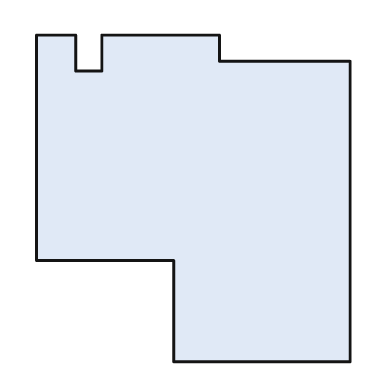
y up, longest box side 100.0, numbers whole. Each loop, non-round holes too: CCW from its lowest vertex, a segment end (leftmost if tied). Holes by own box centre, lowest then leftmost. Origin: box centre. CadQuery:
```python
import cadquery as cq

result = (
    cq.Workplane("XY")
    .moveTo(-6.0, -50.0)
    .lineTo(48.0, -50.0)
    .lineTo(48.0, 42.0)
    .lineTo(8.0, 42.0)
    .lineTo(8.0, 50.0)
    .lineTo(-28.0, 50.0)
    .lineTo(-28.0, 39.0)
    .lineTo(-36.0, 39.0)
    .lineTo(-36.0, 50.0)
    .lineTo(-48.0, 50.0)
    .lineTo(-48.0, -19.0)
    .lineTo(-6.0, -19.0)
    .close()
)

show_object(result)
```